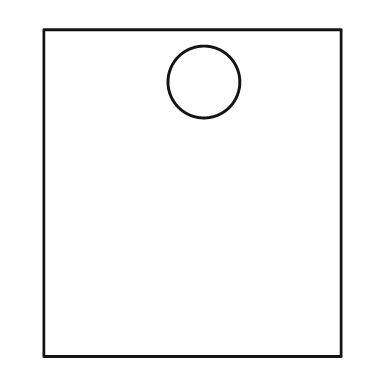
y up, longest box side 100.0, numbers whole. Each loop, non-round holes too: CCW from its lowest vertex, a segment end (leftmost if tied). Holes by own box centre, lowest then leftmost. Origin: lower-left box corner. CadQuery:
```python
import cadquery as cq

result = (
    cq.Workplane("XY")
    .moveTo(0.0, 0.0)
    .lineTo(91.0, 0.0)
    .lineTo(91.0, 100.0)
    .lineTo(0.0, 100.0)
    .close()
    .moveTo(49.0, 84.0)
    .circle(11.0)
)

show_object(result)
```